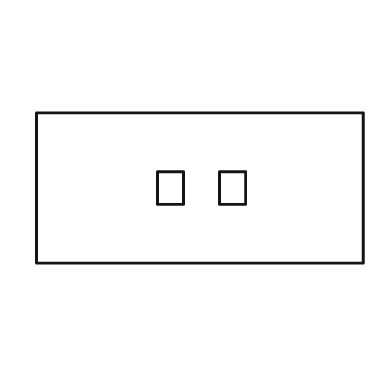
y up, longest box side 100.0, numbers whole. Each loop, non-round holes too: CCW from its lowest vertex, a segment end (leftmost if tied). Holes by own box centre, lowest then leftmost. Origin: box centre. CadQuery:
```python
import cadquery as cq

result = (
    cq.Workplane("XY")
    .moveTo(-50.0, -23.0)
    .lineTo(50.0, -23.0)
    .lineTo(50.0, 23.0)
    .lineTo(-50.0, 23.0)
    .close()
    .moveTo(-13.0, -5.0)
    .lineTo(-5.0, -5.0)
    .lineTo(-5.0, 5.0)
    .lineTo(-13.0, 5.0)
    .close()
    .moveTo(6.0, -5.0)
    .lineTo(14.0, -5.0)
    .lineTo(14.0, 5.0)
    .lineTo(6.0, 5.0)
    .close()
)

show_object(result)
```